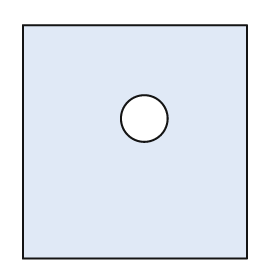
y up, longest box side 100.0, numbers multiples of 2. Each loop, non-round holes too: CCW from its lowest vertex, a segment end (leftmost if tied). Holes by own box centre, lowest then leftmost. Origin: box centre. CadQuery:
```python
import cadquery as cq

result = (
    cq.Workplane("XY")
    .moveTo(-48.0, -50.0)
    .lineTo(48.0, -50.0)
    .lineTo(48.0, 50.0)
    .lineTo(-48.0, 50.0)
    .close()
    .moveTo(4.0, 10.0)
    .circle(10.0)
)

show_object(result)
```